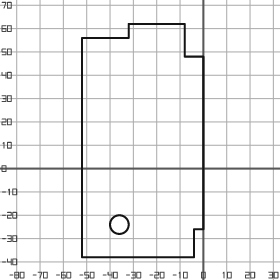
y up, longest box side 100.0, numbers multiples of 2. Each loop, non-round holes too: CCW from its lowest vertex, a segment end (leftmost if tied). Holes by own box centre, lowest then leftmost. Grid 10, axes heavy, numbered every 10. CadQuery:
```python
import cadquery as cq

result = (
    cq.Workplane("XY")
    .moveTo(-52.0, -38.0)
    .lineTo(-4.0, -38.0)
    .lineTo(-4.0, -26.0)
    .lineTo(0.0, -26.0)
    .lineTo(0.0, 48.0)
    .lineTo(-8.0, 48.0)
    .lineTo(-8.0, 62.0)
    .lineTo(-32.0, 62.0)
    .lineTo(-32.0, 56.0)
    .lineTo(-52.0, 56.0)
    .close()
    .moveTo(-36.0, -24.0)
    .circle(4.0)
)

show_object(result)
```